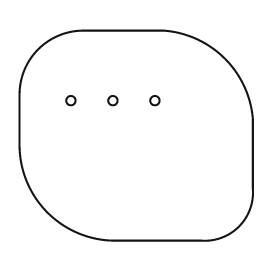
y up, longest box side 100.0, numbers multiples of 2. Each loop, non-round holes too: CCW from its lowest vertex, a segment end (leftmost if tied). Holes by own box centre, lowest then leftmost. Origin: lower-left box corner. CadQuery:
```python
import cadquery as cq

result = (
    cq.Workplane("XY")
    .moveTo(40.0, 0.0)
    .lineTo(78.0, 0.0)
    .threePointArc((94.0, 6.0), (100.0, 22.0))
    .lineTo(100.0, 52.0)
    .threePointArc((88.0, 78.0), (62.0, 90.0))
    .lineTo(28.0, 90.0)
    .threePointArc((8.0, 82.0), (0.0, 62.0))
    .lineTo(0.0, 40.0)
    .threePointArc((12.0, 12.0), (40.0, 0.0))
    .close()
    .moveTo(22.0, 60.0)
    .circle(2.0)
    .moveTo(40.0, 60.0)
    .circle(2.0)
    .moveTo(58.0, 60.0)
    .circle(2.0)
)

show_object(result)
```